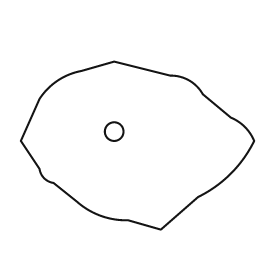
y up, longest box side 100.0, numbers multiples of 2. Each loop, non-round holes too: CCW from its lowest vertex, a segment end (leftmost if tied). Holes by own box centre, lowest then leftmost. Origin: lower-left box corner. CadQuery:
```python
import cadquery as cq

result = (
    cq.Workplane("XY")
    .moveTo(60.0, 0.0)
    .lineTo(76.0, 14.0)
    .threePointArc((90.0, 24.0), (100.0, 38.0))
    .threePointArc((96.0, 44.0), (90.0, 48.0))
    .lineTo(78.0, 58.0)
    .threePointArc((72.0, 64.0), (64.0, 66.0))
    .lineTo(40.0, 72.0)
    .lineTo(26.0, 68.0)
    .threePointArc((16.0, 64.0), (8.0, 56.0))
    .lineTo(0.0, 38.0)
    .lineTo(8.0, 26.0)
    .threePointArc((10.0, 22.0), (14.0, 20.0))
    .lineTo(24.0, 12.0)
    .threePointArc((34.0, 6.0), (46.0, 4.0))
    .close()
    .moveTo(40.0, 42.0)
    .circle(4.0)
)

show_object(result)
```